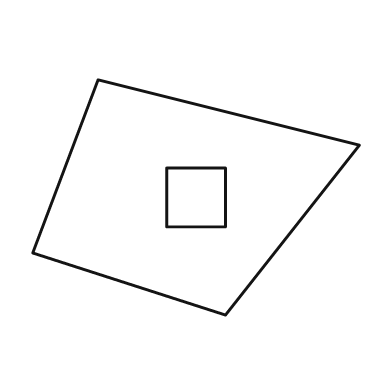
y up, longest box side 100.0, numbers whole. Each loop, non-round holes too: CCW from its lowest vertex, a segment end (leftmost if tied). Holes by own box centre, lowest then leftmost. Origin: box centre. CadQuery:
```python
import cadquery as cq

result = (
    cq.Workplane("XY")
    .moveTo(9.0, -36.0)
    .lineTo(50.0, 16.0)
    .lineTo(-30.0, 36.0)
    .lineTo(-50.0, -17.0)
    .close()
    .moveTo(-9.0, -9.0)
    .lineTo(9.0, -9.0)
    .lineTo(9.0, 9.0)
    .lineTo(-9.0, 9.0)
    .close()
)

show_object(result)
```